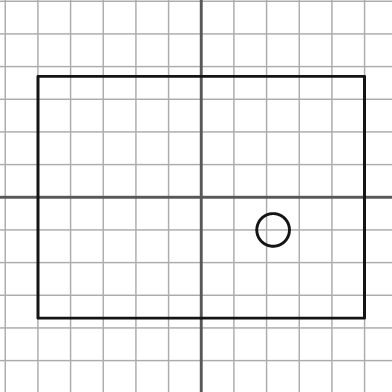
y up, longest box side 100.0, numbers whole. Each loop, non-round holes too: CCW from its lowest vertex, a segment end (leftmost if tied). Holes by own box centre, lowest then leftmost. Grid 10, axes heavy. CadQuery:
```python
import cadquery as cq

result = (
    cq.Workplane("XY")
    .moveTo(-50.0, -37.0)
    .lineTo(50.0, -37.0)
    .lineTo(50.0, 37.0)
    .lineTo(-50.0, 37.0)
    .close()
    .moveTo(22.0, -10.0)
    .circle(5.0)
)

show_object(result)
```